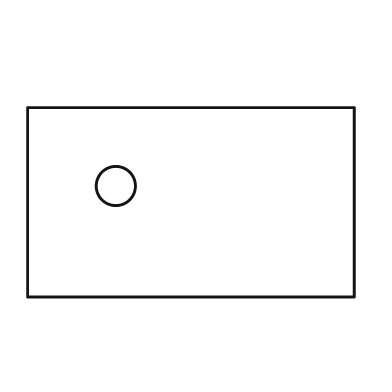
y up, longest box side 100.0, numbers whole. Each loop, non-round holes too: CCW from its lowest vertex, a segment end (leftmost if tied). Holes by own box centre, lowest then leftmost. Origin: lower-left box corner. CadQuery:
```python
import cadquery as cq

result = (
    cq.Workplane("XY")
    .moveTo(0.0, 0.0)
    .lineTo(100.0, 0.0)
    .lineTo(100.0, 58.0)
    .lineTo(0.0, 58.0)
    .close()
    .moveTo(27.0, 34.0)
    .circle(6.0)
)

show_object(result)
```